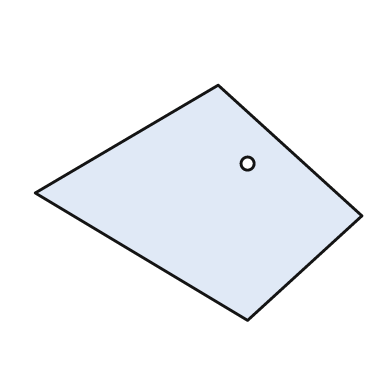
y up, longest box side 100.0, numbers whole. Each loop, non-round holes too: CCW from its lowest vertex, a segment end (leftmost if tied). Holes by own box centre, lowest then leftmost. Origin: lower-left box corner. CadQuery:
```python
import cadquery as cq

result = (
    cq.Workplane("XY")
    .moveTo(65.0, 0.0)
    .lineTo(100.0, 32.0)
    .lineTo(56.0, 72.0)
    .lineTo(0.0, 39.0)
    .close()
    .moveTo(65.0, 48.0)
    .circle(2.0)
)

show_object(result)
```